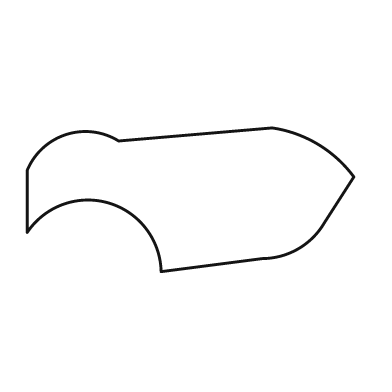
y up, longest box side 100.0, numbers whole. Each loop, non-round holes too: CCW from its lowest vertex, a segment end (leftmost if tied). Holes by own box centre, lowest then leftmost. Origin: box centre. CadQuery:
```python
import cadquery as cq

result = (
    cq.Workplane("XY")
    .moveTo(-9.0, -22.0)
    .lineTo(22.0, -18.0)
    .threePointArc((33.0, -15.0), (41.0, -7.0))
    .lineTo(50.0, 7.0)
    .threePointArc((39.0, 17.0), (25.0, 22.0))
    .lineTo(-22.0, 18.0)
    .threePointArc((-38.0, 20.0), (-50.0, 9.0))
    .lineTo(-50.0, -10.0)
    .threePointArc((-25.0, -1.0), (-9.0, -22.0))
    .close()
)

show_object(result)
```